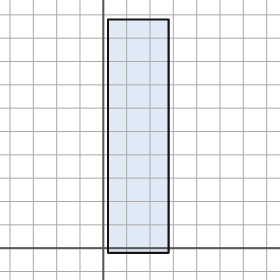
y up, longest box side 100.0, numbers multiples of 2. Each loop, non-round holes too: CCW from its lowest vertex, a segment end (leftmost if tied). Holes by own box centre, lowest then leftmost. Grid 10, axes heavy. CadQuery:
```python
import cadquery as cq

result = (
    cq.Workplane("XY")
    .moveTo(2.0, -2.0)
    .lineTo(28.0, -2.0)
    .lineTo(28.0, 98.0)
    .lineTo(2.0, 98.0)
    .close()
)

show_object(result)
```